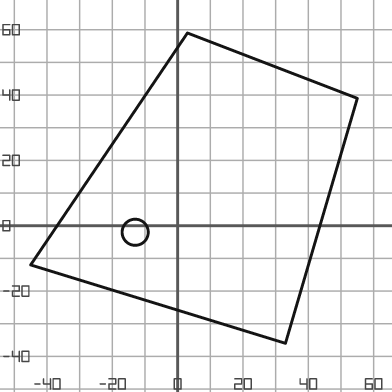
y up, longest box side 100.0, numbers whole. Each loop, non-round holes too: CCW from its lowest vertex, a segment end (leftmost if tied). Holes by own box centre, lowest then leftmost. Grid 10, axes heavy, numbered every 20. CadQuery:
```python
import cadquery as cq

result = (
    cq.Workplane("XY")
    .moveTo(33.0, -36.0)
    .lineTo(55.0, 39.0)
    .lineTo(3.0, 59.0)
    .lineTo(-45.0, -12.0)
    .close()
    .moveTo(-13.0, -2.0)
    .circle(4.0)
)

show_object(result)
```